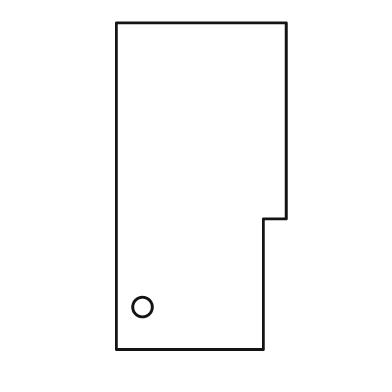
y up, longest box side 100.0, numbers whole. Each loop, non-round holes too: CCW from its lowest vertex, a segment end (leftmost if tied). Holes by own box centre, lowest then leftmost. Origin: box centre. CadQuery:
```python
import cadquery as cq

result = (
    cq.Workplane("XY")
    .moveTo(-26.0, -50.0)
    .lineTo(19.0, -50.0)
    .lineTo(19.0, -10.0)
    .lineTo(26.0, -10.0)
    .lineTo(26.0, 50.0)
    .lineTo(-26.0, 50.0)
    .close()
    .moveTo(-18.0, -37.0)
    .circle(3.0)
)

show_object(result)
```